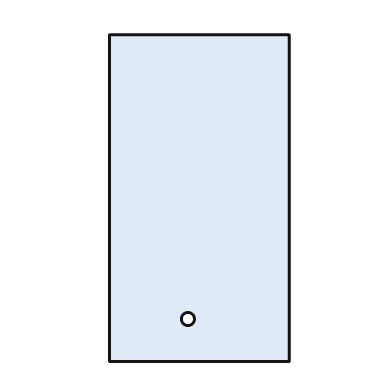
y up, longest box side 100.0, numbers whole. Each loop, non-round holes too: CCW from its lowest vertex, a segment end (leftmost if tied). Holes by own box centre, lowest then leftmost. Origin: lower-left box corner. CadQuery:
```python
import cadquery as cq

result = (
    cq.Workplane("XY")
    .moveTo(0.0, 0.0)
    .lineTo(55.0, 0.0)
    .lineTo(55.0, 100.0)
    .lineTo(0.0, 100.0)
    .close()
    .moveTo(24.0, 13.0)
    .circle(2.0)
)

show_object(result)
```